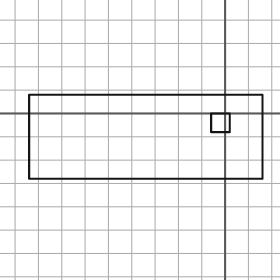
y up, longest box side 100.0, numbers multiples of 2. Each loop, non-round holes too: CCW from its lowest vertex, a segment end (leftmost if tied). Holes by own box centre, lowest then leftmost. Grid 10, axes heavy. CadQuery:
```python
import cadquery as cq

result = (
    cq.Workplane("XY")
    .moveTo(-84.0, -28.0)
    .lineTo(16.0, -28.0)
    .lineTo(16.0, 8.0)
    .lineTo(-84.0, 8.0)
    .close()
    .moveTo(-6.0, -8.0)
    .lineTo(2.0, -8.0)
    .lineTo(2.0, 0.0)
    .lineTo(-6.0, 0.0)
    .close()
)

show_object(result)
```